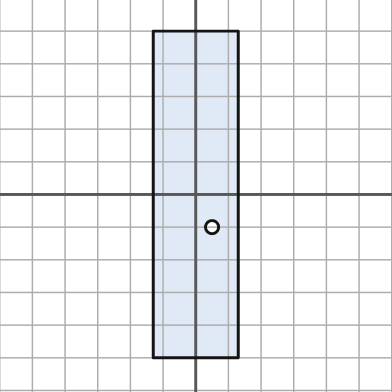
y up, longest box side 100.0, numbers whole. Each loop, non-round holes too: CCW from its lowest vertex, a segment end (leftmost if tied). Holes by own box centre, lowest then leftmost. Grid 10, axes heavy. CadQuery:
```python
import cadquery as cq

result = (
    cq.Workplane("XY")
    .moveTo(-13.0, -50.0)
    .lineTo(13.0, -50.0)
    .lineTo(13.0, 50.0)
    .lineTo(-13.0, 50.0)
    .close()
    .moveTo(5.0, -10.0)
    .circle(2.0)
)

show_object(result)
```